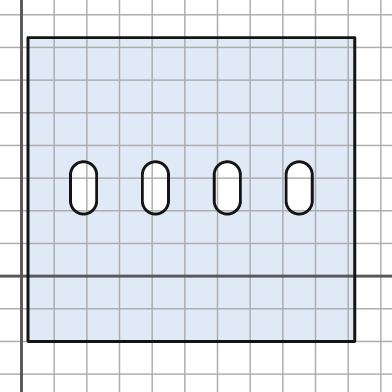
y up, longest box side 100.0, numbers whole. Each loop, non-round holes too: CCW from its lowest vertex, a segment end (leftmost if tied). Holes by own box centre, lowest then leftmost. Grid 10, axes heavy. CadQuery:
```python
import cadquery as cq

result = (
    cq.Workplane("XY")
    .moveTo(2.0, -20.0)
    .lineTo(102.0, -20.0)
    .lineTo(102.0, 73.0)
    .lineTo(2.0, 73.0)
    .close()
    .moveTo(15.0, 23.0)
    .threePointArc((19.0, 19.0), (23.0, 23.0))
    .lineTo(23.0, 31.0)
    .threePointArc((19.0, 35.0), (15.0, 31.0))
    .close()
    .moveTo(37.0, 23.0)
    .threePointArc((41.0, 19.0), (45.0, 23.0))
    .lineTo(45.0, 31.0)
    .threePointArc((41.0, 35.0), (37.0, 31.0))
    .close()
    .moveTo(59.0, 23.0)
    .threePointArc((63.0, 19.0), (67.0, 23.0))
    .lineTo(67.0, 31.0)
    .threePointArc((63.0, 35.0), (59.0, 31.0))
    .close()
    .moveTo(81.0, 23.0)
    .threePointArc((85.0, 19.0), (89.0, 23.0))
    .lineTo(89.0, 31.0)
    .threePointArc((85.0, 35.0), (81.0, 31.0))
    .close()
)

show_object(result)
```